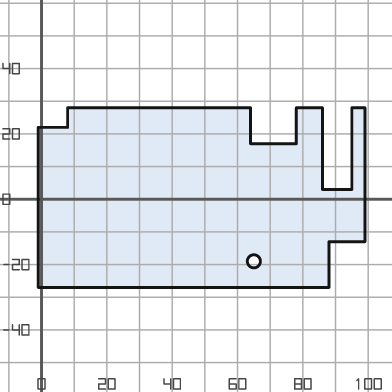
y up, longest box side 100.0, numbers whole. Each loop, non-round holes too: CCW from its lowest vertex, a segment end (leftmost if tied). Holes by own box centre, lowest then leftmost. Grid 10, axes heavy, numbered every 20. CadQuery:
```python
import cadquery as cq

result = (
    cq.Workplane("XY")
    .moveTo(-1.0, -27.0)
    .lineTo(88.0, -27.0)
    .lineTo(88.0, -13.0)
    .lineTo(99.0, -13.0)
    .lineTo(99.0, 28.0)
    .lineTo(95.0, 28.0)
    .lineTo(95.0, 3.0)
    .lineTo(86.0, 3.0)
    .lineTo(86.0, 28.0)
    .lineTo(78.0, 28.0)
    .lineTo(78.0, 17.0)
    .lineTo(64.0, 17.0)
    .lineTo(64.0, 28.0)
    .lineTo(8.0, 28.0)
    .lineTo(8.0, 22.0)
    .lineTo(-1.0, 22.0)
    .close()
    .moveTo(65.0, -19.0)
    .circle(2.0)
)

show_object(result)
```